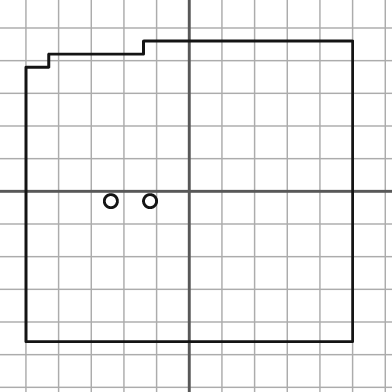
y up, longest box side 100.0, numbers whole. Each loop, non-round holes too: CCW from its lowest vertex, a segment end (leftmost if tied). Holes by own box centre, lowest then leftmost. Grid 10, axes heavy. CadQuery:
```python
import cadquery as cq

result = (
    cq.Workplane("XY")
    .moveTo(-50.0, -46.0)
    .lineTo(50.0, -46.0)
    .lineTo(50.0, 46.0)
    .lineTo(-14.0, 46.0)
    .lineTo(-14.0, 42.0)
    .lineTo(-43.0, 42.0)
    .lineTo(-43.0, 38.0)
    .lineTo(-50.0, 38.0)
    .close()
    .moveTo(-24.0, -3.0)
    .circle(2.0)
    .moveTo(-12.0, -3.0)
    .circle(2.0)
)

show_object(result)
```